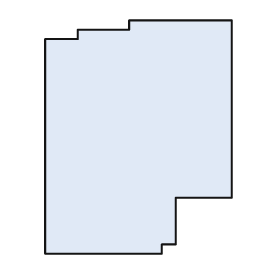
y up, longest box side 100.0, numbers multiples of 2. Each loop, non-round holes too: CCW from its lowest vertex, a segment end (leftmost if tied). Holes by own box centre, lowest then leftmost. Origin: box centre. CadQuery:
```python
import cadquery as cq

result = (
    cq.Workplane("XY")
    .moveTo(-40.0, -50.0)
    .lineTo(10.0, -50.0)
    .lineTo(10.0, -46.0)
    .lineTo(16.0, -46.0)
    .lineTo(16.0, -26.0)
    .lineTo(40.0, -26.0)
    .lineTo(40.0, 50.0)
    .lineTo(-4.0, 50.0)
    .lineTo(-4.0, 46.0)
    .lineTo(-26.0, 46.0)
    .lineTo(-26.0, 42.0)
    .lineTo(-40.0, 42.0)
    .close()
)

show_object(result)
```